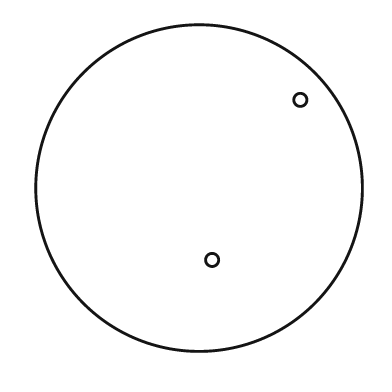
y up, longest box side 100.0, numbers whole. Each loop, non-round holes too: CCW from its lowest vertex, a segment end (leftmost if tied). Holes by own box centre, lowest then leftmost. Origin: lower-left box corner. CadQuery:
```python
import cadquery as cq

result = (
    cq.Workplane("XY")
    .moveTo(50.0, 50.0)
    .circle(50.0)
    .moveTo(54.0, 28.0)
    .circle(2.0)
    .moveTo(81.0, 77.0)
    .circle(2.0)
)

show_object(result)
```